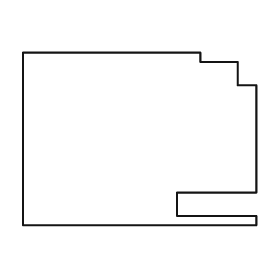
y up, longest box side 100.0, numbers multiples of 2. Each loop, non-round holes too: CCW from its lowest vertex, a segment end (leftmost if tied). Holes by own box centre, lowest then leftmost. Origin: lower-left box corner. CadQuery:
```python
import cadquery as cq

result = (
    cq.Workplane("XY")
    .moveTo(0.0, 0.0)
    .lineTo(100.0, 0.0)
    .lineTo(100.0, 4.0)
    .lineTo(66.0, 4.0)
    .lineTo(66.0, 14.0)
    .lineTo(100.0, 14.0)
    .lineTo(100.0, 60.0)
    .lineTo(92.0, 60.0)
    .lineTo(92.0, 70.0)
    .lineTo(76.0, 70.0)
    .lineTo(76.0, 74.0)
    .lineTo(0.0, 74.0)
    .close()
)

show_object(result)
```